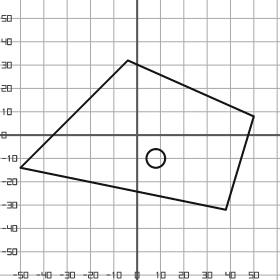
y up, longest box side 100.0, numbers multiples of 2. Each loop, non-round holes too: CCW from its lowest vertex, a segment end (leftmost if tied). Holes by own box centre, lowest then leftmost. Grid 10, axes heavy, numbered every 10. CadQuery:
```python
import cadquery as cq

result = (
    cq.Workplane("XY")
    .moveTo(38.0, -32.0)
    .lineTo(50.0, 8.0)
    .lineTo(-4.0, 32.0)
    .lineTo(-50.0, -14.0)
    .close()
    .moveTo(8.0, -10.0)
    .circle(4.0)
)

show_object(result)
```